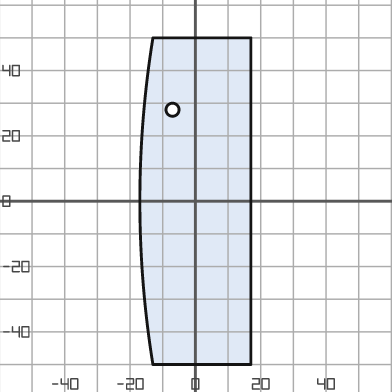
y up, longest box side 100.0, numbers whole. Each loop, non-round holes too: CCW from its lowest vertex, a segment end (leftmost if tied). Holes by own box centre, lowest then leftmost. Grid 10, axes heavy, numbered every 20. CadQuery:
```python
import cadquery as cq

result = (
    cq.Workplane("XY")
    .moveTo(-13.0, -50.0)
    .lineTo(17.0, -50.0)
    .lineTo(17.0, 50.0)
    .lineTo(-13.0, 50.0)
    .threePointArc((-17.0, 0.0), (-13.0, -50.0))
    .close()
    .moveTo(-7.0, 28.0)
    .circle(2.0)
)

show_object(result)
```